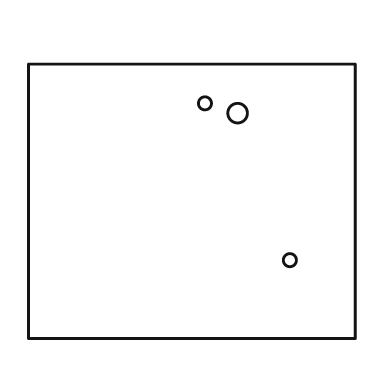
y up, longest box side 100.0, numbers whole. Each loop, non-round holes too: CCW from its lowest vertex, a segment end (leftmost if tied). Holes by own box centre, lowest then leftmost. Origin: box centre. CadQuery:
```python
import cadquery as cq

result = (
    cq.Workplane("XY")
    .moveTo(-50.0, -42.0)
    .lineTo(50.0, -42.0)
    .lineTo(50.0, 42.0)
    .lineTo(-50.0, 42.0)
    .close()
    .moveTo(30.0, -18.0)
    .circle(2.0)
    .moveTo(14.0, 27.0)
    .circle(3.0)
    .moveTo(4.0, 30.0)
    .circle(2.0)
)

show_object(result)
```